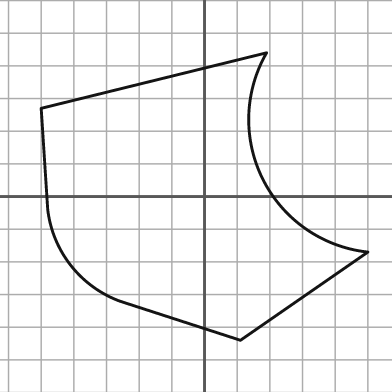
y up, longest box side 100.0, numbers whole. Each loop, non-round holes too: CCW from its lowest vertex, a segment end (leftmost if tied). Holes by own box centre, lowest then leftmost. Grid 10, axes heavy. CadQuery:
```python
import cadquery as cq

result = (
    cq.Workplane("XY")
    .moveTo(11.0, -44.0)
    .lineTo(50.0, -17.0)
    .threePointArc((18.0, 5.0), (19.0, 44.0))
    .lineTo(-50.0, 27.0)
    .lineTo(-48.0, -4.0)
    .threePointArc((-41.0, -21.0), (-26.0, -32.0))
    .close()
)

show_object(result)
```